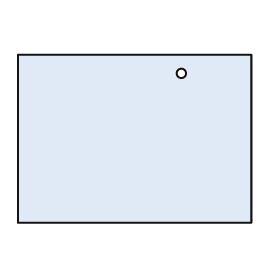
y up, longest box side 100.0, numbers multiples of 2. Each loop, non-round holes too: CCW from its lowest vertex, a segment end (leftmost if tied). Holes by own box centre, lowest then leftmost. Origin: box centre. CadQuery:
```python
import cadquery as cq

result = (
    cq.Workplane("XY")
    .moveTo(-50.0, -36.0)
    .lineTo(50.0, -36.0)
    .lineTo(50.0, 36.0)
    .lineTo(-50.0, 36.0)
    .close()
    .moveTo(20.0, 28.0)
    .circle(2.0)
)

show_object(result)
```